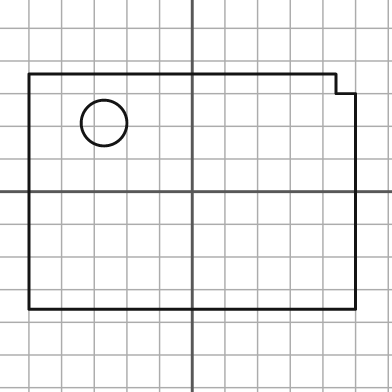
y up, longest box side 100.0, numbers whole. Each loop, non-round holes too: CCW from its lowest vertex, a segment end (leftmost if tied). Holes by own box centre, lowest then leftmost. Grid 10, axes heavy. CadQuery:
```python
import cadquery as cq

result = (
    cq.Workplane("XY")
    .moveTo(-50.0, -36.0)
    .lineTo(50.0, -36.0)
    .lineTo(50.0, 30.0)
    .lineTo(44.0, 30.0)
    .lineTo(44.0, 36.0)
    .lineTo(-50.0, 36.0)
    .close()
    .moveTo(-27.0, 21.0)
    .circle(7.0)
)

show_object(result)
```